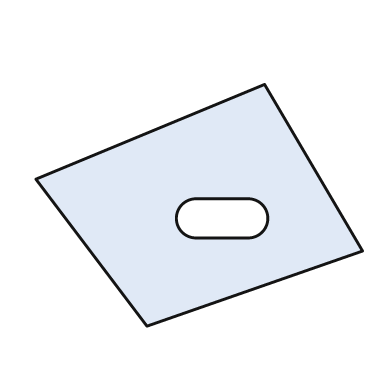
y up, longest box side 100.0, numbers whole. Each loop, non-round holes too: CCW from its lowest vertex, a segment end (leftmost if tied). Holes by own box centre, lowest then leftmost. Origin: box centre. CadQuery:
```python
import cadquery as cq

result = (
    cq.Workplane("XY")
    .moveTo(-16.0, -37.0)
    .lineTo(50.0, -14.0)
    .lineTo(20.0, 37.0)
    .lineTo(-50.0, 8.0)
    .close()
    .moveTo(-1.0, -10.0)
    .lineTo(15.0, -10.0)
    .threePointArc((21.0, -4.0), (15.0, 2.0))
    .lineTo(-1.0, 2.0)
    .threePointArc((-7.0, -4.0), (-1.0, -10.0))
    .close()
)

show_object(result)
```